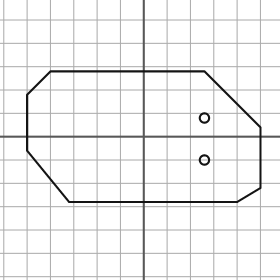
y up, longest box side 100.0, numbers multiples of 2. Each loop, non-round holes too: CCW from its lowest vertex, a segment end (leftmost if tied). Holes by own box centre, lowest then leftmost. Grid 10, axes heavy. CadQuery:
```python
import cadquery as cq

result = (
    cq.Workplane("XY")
    .moveTo(-32.0, -28.0)
    .lineTo(40.0, -28.0)
    .lineTo(50.0, -22.0)
    .lineTo(50.0, 4.0)
    .lineTo(26.0, 28.0)
    .lineTo(-40.0, 28.0)
    .lineTo(-50.0, 18.0)
    .lineTo(-50.0, -6.0)
    .close()
    .moveTo(26.0, -10.0)
    .circle(2.0)
    .moveTo(26.0, 8.0)
    .circle(2.0)
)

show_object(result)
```